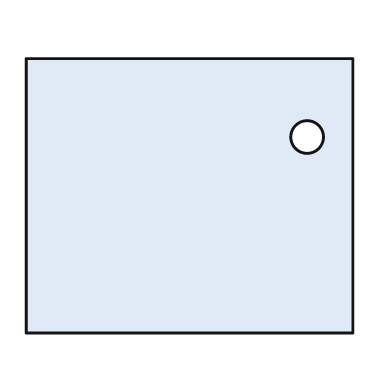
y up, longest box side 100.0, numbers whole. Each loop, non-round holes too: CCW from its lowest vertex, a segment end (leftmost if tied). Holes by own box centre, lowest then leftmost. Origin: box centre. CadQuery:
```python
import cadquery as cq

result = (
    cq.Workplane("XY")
    .moveTo(-50.0, -42.0)
    .lineTo(50.0, -42.0)
    .lineTo(50.0, 42.0)
    .lineTo(-50.0, 42.0)
    .close()
    .moveTo(36.0, 18.0)
    .circle(5.0)
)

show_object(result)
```